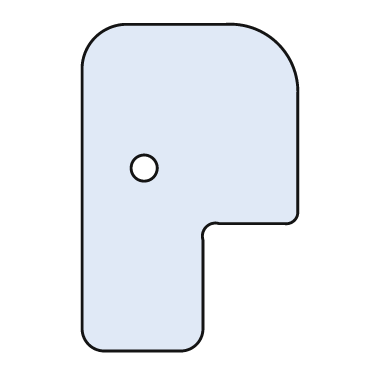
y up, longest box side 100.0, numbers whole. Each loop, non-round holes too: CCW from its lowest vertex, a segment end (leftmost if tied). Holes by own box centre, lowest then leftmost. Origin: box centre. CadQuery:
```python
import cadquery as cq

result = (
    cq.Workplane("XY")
    .moveTo(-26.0, -50.0)
    .lineTo(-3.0, -50.0)
    .threePointArc((2.0, -48.0), (4.0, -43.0))
    .lineTo(4.0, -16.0)
    .threePointArc((5.0, -12.0), (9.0, -11.0))
    .lineTo(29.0, -11.0)
    .threePointArc((32.0, -10.0), (33.0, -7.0))
    .lineTo(33.0, 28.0)
    .threePointArc((27.0, 44.0), (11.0, 50.0))
    .lineTo(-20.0, 50.0)
    .threePointArc((-29.0, 46.0), (-33.0, 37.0))
    .lineTo(-33.0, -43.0)
    .threePointArc((-31.0, -48.0), (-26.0, -50.0))
    .close()
    .moveTo(-14.0, 6.0)
    .circle(4.0)
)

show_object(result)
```